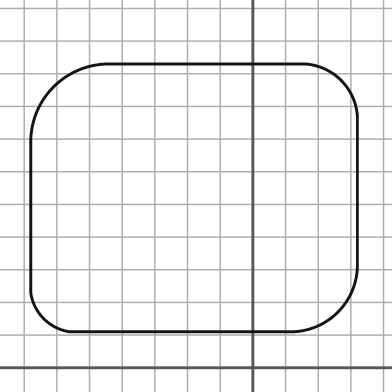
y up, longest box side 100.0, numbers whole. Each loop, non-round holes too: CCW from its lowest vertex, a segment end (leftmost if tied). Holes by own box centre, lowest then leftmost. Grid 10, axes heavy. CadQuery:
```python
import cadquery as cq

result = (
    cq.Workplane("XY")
    .moveTo(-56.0, 11.0)
    .lineTo(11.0, 11.0)
    .threePointArc((26.0, 17.0), (32.0, 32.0))
    .lineTo(32.0, 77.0)
    .threePointArc((27.0, 88.0), (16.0, 93.0))
    .lineTo(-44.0, 93.0)
    .threePointArc((-61.0, 86.0), (-68.0, 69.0))
    .lineTo(-68.0, 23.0)
    .threePointArc((-64.0, 15.0), (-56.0, 11.0))
    .close()
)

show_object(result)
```